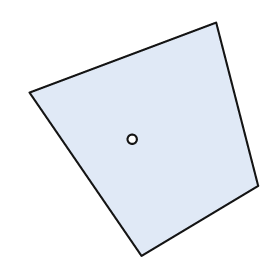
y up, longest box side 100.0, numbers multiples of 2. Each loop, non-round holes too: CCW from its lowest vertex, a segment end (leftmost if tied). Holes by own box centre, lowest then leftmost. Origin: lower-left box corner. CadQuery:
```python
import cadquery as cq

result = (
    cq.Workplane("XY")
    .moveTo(48.0, 0.0)
    .lineTo(98.0, 30.0)
    .lineTo(80.0, 100.0)
    .lineTo(0.0, 70.0)
    .close()
    .moveTo(44.0, 50.0)
    .circle(2.0)
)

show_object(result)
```